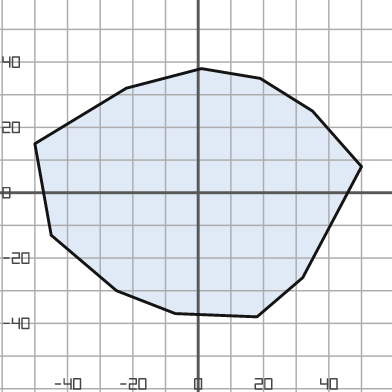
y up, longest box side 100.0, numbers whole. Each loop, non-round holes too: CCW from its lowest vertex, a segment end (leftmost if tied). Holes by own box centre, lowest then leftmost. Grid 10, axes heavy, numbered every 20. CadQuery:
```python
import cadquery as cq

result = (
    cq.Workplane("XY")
    .moveTo(18.0, -38.0)
    .lineTo(32.0, -26.0)
    .lineTo(50.0, 8.0)
    .lineTo(35.0, 25.0)
    .lineTo(19.0, 35.0)
    .lineTo(1.0, 38.0)
    .lineTo(-22.0, 32.0)
    .lineTo(-50.0, 15.0)
    .lineTo(-45.0, -13.0)
    .lineTo(-25.0, -30.0)
    .lineTo(-7.0, -37.0)
    .close()
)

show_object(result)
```